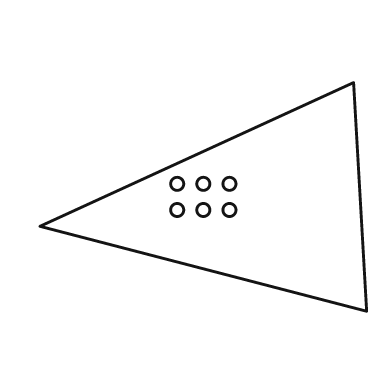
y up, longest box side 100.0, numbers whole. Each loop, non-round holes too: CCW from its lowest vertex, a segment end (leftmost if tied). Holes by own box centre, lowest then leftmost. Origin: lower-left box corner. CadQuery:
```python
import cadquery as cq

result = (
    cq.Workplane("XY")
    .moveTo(100.0, 0.0)
    .lineTo(96.0, 70.0)
    .lineTo(0.0, 26.0)
    .close()
    .moveTo(42.0, 31.0)
    .circle(2.0)
    .moveTo(50.0, 31.0)
    .circle(2.0)
    .moveTo(58.0, 31.0)
    .circle(2.0)
    .moveTo(42.0, 39.0)
    .circle(2.0)
    .moveTo(50.0, 39.0)
    .circle(2.0)
    .moveTo(58.0, 39.0)
    .circle(2.0)
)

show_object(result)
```